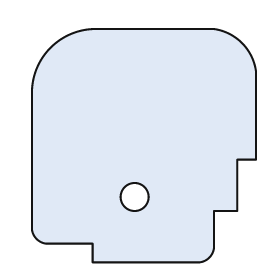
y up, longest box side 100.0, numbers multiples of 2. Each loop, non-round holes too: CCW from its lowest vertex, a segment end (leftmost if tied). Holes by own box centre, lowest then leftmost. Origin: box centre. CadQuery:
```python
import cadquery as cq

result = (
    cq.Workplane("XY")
    .moveTo(-22.0, -50.0)
    .lineTo(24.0, -50.0)
    .threePointArc((28.0, -48.0), (30.0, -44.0))
    .lineTo(30.0, -28.0)
    .lineTo(40.0, -28.0)
    .lineTo(40.0, -6.0)
    .lineTo(48.0, -6.0)
    .lineTo(48.0, 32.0)
    .threePointArc((42.0, 44.0), (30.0, 50.0))
    .lineTo(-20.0, 50.0)
    .threePointArc((-40.0, 42.0), (-48.0, 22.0))
    .lineTo(-48.0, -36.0)
    .threePointArc((-46.0, -40.0), (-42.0, -42.0))
    .lineTo(-22.0, -42.0)
    .close()
    .moveTo(-4.0, -22.0)
    .circle(6.0)
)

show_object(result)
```